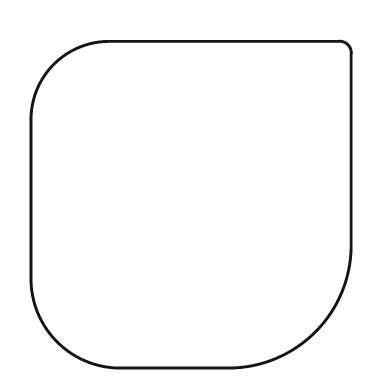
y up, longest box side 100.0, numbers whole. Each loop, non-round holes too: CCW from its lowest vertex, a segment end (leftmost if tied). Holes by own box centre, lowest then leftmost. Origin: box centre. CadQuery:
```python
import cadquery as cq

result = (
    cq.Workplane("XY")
    .moveTo(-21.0, -50.0)
    .lineTo(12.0, -50.0)
    .threePointArc((38.0, -39.0), (49.0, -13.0))
    .lineTo(49.0, 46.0)
    .threePointArc((48.0, 49.0), (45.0, 50.0))
    .lineTo(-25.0, 50.0)
    .threePointArc((-42.0, 43.0), (-49.0, 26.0))
    .lineTo(-49.0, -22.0)
    .threePointArc((-41.0, -42.0), (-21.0, -50.0))
    .close()
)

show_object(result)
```